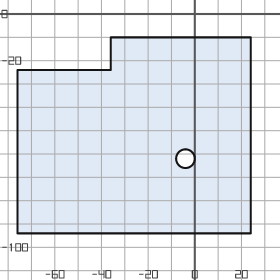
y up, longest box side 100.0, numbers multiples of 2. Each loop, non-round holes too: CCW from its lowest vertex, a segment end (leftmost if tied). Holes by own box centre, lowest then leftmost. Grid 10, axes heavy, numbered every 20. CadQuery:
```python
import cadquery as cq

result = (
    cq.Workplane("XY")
    .moveTo(-76.0, -94.0)
    .lineTo(24.0, -94.0)
    .lineTo(24.0, -10.0)
    .lineTo(-36.0, -10.0)
    .lineTo(-36.0, -24.0)
    .lineTo(-76.0, -24.0)
    .close()
    .moveTo(-4.0, -62.0)
    .circle(4.0)
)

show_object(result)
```